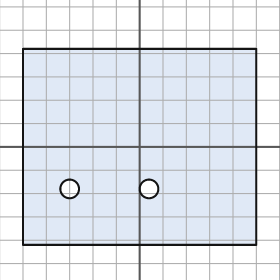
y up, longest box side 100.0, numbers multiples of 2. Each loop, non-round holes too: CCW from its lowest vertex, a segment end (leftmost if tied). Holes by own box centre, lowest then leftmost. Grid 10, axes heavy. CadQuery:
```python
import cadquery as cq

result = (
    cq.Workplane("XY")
    .moveTo(-50.0, -42.0)
    .lineTo(50.0, -42.0)
    .lineTo(50.0, 42.0)
    .lineTo(-50.0, 42.0)
    .close()
    .moveTo(-30.0, -18.0)
    .circle(4.0)
    .moveTo(4.0, -18.0)
    .circle(4.0)
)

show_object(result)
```